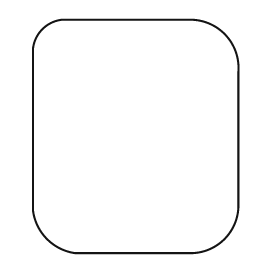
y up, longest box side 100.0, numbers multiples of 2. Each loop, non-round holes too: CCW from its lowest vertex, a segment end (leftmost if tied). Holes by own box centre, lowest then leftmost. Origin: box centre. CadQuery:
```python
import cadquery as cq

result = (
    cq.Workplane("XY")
    .moveTo(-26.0, -50.0)
    .lineTo(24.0, -50.0)
    .threePointArc((38.0, -44.0), (44.0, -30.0))
    .lineTo(44.0, 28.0)
    .threePointArc((38.0, 44.0), (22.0, 50.0))
    .lineTo(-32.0, 50.0)
    .threePointArc((-40.0, 46.0), (-44.0, 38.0))
    .lineTo(-44.0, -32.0)
    .threePointArc((-38.0, -44.0), (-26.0, -50.0))
    .close()
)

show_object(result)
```